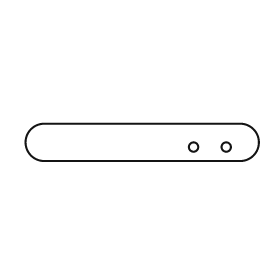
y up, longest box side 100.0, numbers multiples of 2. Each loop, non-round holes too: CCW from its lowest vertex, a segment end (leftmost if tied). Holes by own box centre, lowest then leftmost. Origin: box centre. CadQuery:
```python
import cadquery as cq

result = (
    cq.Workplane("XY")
    .moveTo(-42.0, -8.0)
    .lineTo(42.0, -8.0)
    .threePointArc((50.0, 0.0), (42.0, 8.0))
    .lineTo(-42.0, 8.0)
    .threePointArc((-50.0, 0.0), (-42.0, -8.0))
    .close()
    .moveTo(22.0, -2.0)
    .circle(2.0)
    .moveTo(36.0, -2.0)
    .circle(2.0)
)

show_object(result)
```